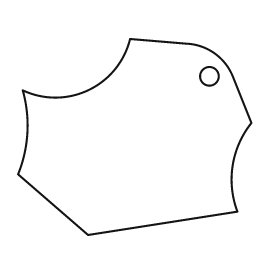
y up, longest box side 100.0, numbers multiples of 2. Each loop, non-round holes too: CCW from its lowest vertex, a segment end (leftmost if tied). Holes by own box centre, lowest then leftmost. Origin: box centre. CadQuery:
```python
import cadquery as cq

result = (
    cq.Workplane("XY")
    .moveTo(-20.0, -42.0)
    .lineTo(44.0, -32.0)
    .threePointArc((42.0, -12.0), (50.0, 6.0))
    .lineTo(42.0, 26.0)
    .threePointArc((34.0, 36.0), (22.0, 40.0))
    .lineTo(-2.0, 42.0)
    .threePointArc((-20.0, 20.0), (-48.0, 20.0))
    .threePointArc((-46.0, 2.0), (-50.0, -16.0))
    .close()
    .moveTo(32.0, 26.0)
    .circle(4.0)
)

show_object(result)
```